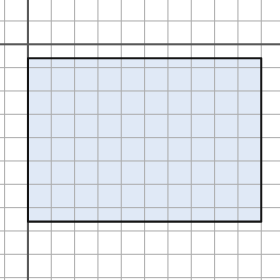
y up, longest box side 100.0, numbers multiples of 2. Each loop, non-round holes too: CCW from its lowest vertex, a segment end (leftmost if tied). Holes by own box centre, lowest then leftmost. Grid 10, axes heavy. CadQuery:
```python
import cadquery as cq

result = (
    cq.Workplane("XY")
    .moveTo(0.0, -76.0)
    .lineTo(100.0, -76.0)
    .lineTo(100.0, -6.0)
    .lineTo(0.0, -6.0)
    .close()
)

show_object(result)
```